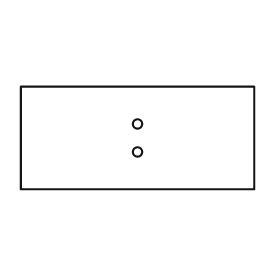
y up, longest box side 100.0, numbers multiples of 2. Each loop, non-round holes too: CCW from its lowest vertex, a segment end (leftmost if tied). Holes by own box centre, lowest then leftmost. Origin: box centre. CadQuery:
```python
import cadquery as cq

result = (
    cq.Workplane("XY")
    .moveTo(-50.0, -22.0)
    .lineTo(50.0, -22.0)
    .lineTo(50.0, 22.0)
    .lineTo(-50.0, 22.0)
    .close()
    .moveTo(0.0, -6.0)
    .circle(2.0)
    .moveTo(0.0, 6.0)
    .circle(2.0)
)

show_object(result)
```